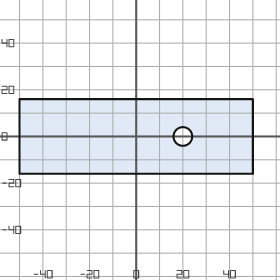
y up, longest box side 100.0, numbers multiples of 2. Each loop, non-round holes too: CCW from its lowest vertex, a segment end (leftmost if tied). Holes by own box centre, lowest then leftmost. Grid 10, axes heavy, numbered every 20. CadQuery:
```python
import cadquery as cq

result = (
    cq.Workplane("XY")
    .moveTo(-50.0, -16.0)
    .lineTo(50.0, -16.0)
    .lineTo(50.0, 16.0)
    .lineTo(-50.0, 16.0)
    .close()
    .moveTo(20.0, 0.0)
    .circle(4.0)
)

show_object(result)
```